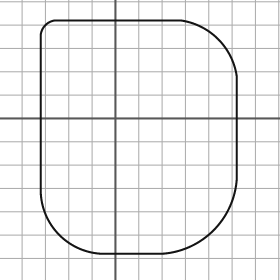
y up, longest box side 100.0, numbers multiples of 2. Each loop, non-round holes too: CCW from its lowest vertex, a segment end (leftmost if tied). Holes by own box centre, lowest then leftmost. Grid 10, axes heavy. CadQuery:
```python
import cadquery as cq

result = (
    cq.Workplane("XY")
    .moveTo(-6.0, -58.0)
    .lineTo(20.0, -58.0)
    .threePointArc((42.0, -48.0), (52.0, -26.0))
    .lineTo(52.0, 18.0)
    .threePointArc((44.0, 34.0), (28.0, 42.0))
    .lineTo(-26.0, 42.0)
    .threePointArc((-30.0, 40.0), (-32.0, 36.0))
    .lineTo(-32.0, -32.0)
    .threePointArc((-24.0, -50.0), (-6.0, -58.0))
    .close()
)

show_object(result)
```